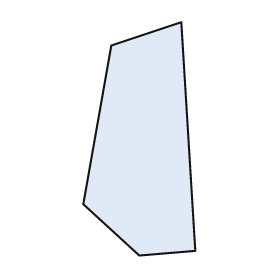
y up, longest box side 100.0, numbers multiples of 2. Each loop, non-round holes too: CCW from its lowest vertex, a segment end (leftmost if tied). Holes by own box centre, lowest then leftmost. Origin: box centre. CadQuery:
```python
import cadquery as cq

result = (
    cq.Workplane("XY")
    .moveTo(0.0, -50.0)
    .lineTo(24.0, -48.0)
    .lineTo(18.0, 50.0)
    .lineTo(-12.0, 40.0)
    .lineTo(-24.0, -28.0)
    .close()
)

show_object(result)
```